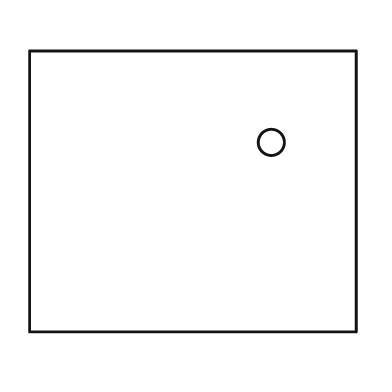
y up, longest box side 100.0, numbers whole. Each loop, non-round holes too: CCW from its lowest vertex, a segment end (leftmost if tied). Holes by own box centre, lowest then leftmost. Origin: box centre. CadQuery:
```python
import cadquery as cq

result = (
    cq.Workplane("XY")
    .moveTo(-50.0, -43.0)
    .lineTo(50.0, -43.0)
    .lineTo(50.0, 43.0)
    .lineTo(-50.0, 43.0)
    .close()
    .moveTo(24.0, 15.0)
    .circle(4.0)
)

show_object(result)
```